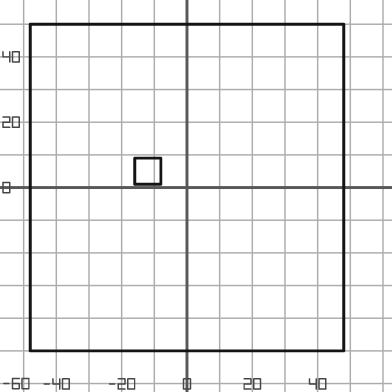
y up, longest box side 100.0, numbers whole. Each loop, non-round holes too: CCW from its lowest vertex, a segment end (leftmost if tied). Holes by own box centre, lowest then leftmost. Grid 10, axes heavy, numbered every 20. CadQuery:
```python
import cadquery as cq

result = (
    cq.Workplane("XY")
    .moveTo(-48.0, -50.0)
    .lineTo(48.0, -50.0)
    .lineTo(48.0, 50.0)
    .lineTo(-48.0, 50.0)
    .close()
    .moveTo(-16.0, 1.0)
    .lineTo(-8.0, 1.0)
    .lineTo(-8.0, 9.0)
    .lineTo(-16.0, 9.0)
    .close()
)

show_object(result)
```